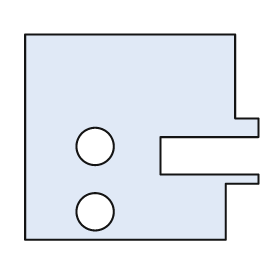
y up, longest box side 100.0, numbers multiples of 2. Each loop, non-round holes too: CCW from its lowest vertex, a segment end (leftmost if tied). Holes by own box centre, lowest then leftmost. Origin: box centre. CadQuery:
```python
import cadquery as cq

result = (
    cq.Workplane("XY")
    .moveTo(-50.0, -44.0)
    .lineTo(36.0, -44.0)
    .lineTo(36.0, -20.0)
    .lineTo(50.0, -20.0)
    .lineTo(50.0, -16.0)
    .lineTo(8.0, -16.0)
    .lineTo(8.0, 0.0)
    .lineTo(50.0, 0.0)
    .lineTo(50.0, 8.0)
    .lineTo(40.0, 8.0)
    .lineTo(40.0, 44.0)
    .lineTo(-50.0, 44.0)
    .close()
    .moveTo(-20.0, -32.0)
    .circle(8.0)
    .moveTo(-20.0, -4.0)
    .circle(8.0)
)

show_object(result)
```